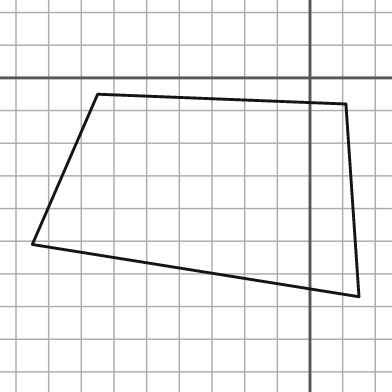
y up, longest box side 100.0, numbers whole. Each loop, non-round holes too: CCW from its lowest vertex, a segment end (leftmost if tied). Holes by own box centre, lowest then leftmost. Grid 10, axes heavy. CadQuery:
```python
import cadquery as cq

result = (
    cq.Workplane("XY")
    .moveTo(15.0, -67.0)
    .lineTo(11.0, -8.0)
    .lineTo(-65.0, -5.0)
    .lineTo(-85.0, -51.0)
    .close()
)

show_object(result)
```